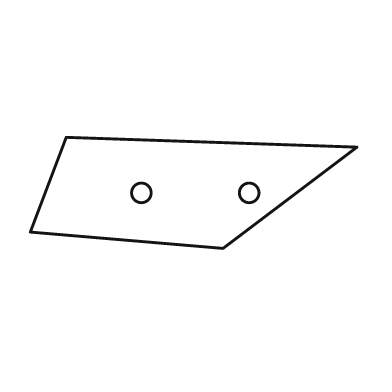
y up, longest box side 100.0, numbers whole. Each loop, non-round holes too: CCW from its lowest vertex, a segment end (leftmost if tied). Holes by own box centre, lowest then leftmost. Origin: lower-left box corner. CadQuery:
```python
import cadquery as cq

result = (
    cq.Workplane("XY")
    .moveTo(59.0, 0.0)
    .lineTo(100.0, 31.0)
    .lineTo(11.0, 34.0)
    .lineTo(0.0, 5.0)
    .close()
    .moveTo(34.0, 17.0)
    .circle(3.0)
    .moveTo(67.0, 17.0)
    .circle(3.0)
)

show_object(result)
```